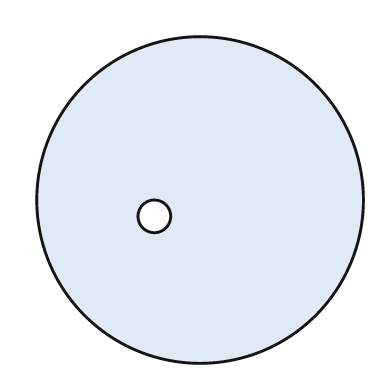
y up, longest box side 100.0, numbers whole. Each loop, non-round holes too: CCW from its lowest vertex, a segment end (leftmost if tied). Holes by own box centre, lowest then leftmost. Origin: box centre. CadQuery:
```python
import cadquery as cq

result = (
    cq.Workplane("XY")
    .moveTo(0.0, 0.0)
    .circle(50.0)
    .moveTo(-14.0, -5.0)
    .circle(5.0)
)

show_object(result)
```